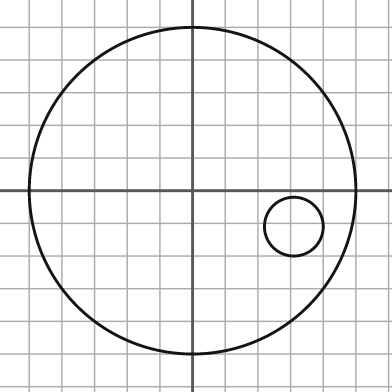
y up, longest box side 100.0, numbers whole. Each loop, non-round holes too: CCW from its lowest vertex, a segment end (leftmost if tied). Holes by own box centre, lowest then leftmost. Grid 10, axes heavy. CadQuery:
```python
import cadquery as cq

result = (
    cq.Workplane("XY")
    .moveTo(0.0, 0.0)
    .circle(50.0)
    .moveTo(31.0, -11.0)
    .circle(9.0)
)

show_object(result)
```